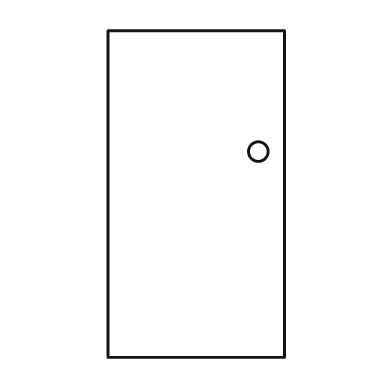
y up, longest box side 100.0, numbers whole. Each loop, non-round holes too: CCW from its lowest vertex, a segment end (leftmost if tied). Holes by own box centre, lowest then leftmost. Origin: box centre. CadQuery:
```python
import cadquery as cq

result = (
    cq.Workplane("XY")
    .moveTo(-27.0, -50.0)
    .lineTo(27.0, -50.0)
    .lineTo(27.0, 50.0)
    .lineTo(-27.0, 50.0)
    .close()
    .moveTo(19.0, 13.0)
    .circle(3.0)
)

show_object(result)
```